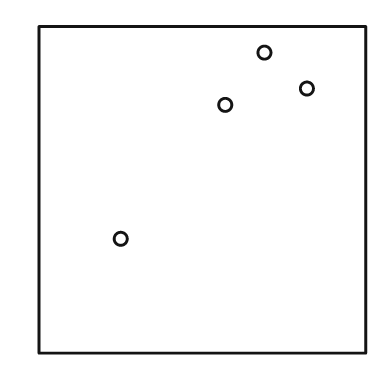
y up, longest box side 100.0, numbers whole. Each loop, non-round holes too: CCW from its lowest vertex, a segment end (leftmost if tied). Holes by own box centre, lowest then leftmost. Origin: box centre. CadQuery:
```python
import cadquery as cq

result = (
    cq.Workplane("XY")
    .moveTo(-50.0, -50.0)
    .lineTo(50.0, -50.0)
    .lineTo(50.0, 50.0)
    .lineTo(-50.0, 50.0)
    .close()
    .moveTo(-25.0, -15.0)
    .circle(2.0)
    .moveTo(7.0, 26.0)
    .circle(2.0)
    .moveTo(32.0, 31.0)
    .circle(2.0)
    .moveTo(19.0, 42.0)
    .circle(2.0)
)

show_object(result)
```